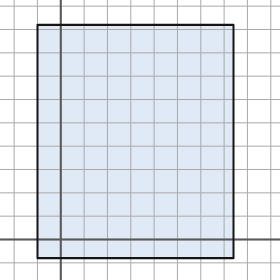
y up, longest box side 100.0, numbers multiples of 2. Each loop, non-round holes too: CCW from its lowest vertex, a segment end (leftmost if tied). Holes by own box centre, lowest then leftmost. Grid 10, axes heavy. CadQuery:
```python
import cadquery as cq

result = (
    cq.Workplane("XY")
    .moveTo(-10.0, -8.0)
    .lineTo(74.0, -8.0)
    .lineTo(74.0, 92.0)
    .lineTo(-10.0, 92.0)
    .close()
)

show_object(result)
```